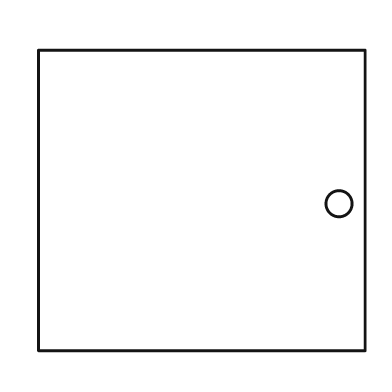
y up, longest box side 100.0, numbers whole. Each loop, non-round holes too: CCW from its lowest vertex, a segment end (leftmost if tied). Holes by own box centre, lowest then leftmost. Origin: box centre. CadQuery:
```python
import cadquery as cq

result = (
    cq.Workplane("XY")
    .moveTo(-50.0, -46.0)
    .lineTo(50.0, -46.0)
    .lineTo(50.0, 46.0)
    .lineTo(-50.0, 46.0)
    .close()
    .moveTo(42.0, -1.0)
    .circle(4.0)
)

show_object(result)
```